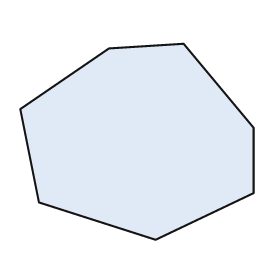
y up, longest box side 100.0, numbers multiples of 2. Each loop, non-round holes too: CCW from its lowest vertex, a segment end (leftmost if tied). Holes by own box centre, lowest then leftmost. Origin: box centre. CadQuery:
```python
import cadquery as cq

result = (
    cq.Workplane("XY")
    .moveTo(8.0, -42.0)
    .lineTo(50.0, -22.0)
    .lineTo(50.0, 6.0)
    .lineTo(20.0, 42.0)
    .lineTo(-12.0, 40.0)
    .lineTo(-50.0, 14.0)
    .lineTo(-42.0, -26.0)
    .close()
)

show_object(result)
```